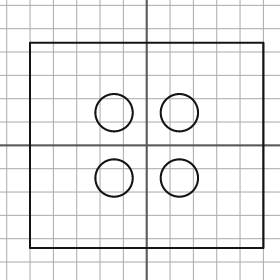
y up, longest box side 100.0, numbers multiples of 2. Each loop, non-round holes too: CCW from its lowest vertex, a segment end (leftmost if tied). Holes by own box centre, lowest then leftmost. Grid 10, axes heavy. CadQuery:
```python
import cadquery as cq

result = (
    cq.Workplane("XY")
    .moveTo(-50.0, -44.0)
    .lineTo(50.0, -44.0)
    .lineTo(50.0, 44.0)
    .lineTo(-50.0, 44.0)
    .close()
    .moveTo(-14.0, -14.0)
    .circle(8.0)
    .moveTo(14.0, -14.0)
    .circle(8.0)
    .moveTo(-14.0, 14.0)
    .circle(8.0)
    .moveTo(14.0, 14.0)
    .circle(8.0)
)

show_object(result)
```